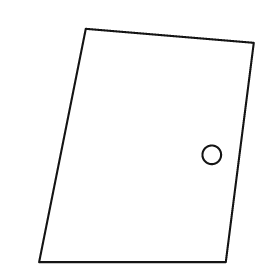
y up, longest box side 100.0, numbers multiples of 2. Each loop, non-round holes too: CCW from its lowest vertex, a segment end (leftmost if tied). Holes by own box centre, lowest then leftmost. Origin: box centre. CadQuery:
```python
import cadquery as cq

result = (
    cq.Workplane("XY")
    .moveTo(-46.0, -50.0)
    .lineTo(34.0, -50.0)
    .lineTo(46.0, 44.0)
    .lineTo(-26.0, 50.0)
    .close()
    .moveTo(28.0, -4.0)
    .circle(4.0)
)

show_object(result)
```